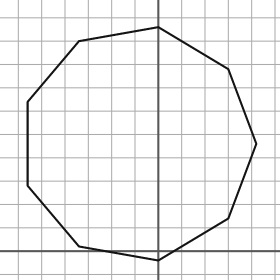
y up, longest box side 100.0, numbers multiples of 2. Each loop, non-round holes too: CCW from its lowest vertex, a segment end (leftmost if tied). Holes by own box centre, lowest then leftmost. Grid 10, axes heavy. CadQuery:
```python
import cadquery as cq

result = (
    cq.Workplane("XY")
    .moveTo(0.0, -4.0)
    .lineTo(30.0, 14.0)
    .lineTo(42.0, 46.0)
    .lineTo(30.0, 78.0)
    .lineTo(0.0, 96.0)
    .lineTo(-34.0, 90.0)
    .lineTo(-56.0, 64.0)
    .lineTo(-56.0, 28.0)
    .lineTo(-34.0, 2.0)
    .close()
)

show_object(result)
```